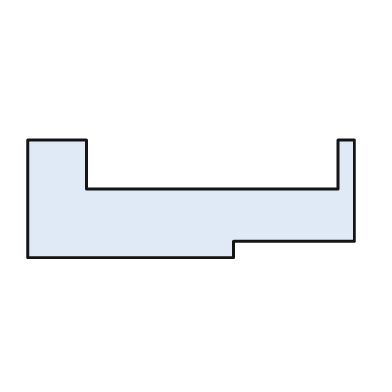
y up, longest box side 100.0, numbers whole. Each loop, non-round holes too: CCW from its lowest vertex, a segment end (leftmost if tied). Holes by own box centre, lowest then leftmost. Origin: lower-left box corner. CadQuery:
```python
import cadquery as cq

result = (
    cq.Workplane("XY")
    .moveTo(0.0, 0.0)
    .lineTo(63.0, 0.0)
    .lineTo(63.0, 5.0)
    .lineTo(100.0, 5.0)
    .lineTo(100.0, 36.0)
    .lineTo(95.0, 36.0)
    .lineTo(95.0, 21.0)
    .lineTo(18.0, 21.0)
    .lineTo(18.0, 36.0)
    .lineTo(0.0, 36.0)
    .close()
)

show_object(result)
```